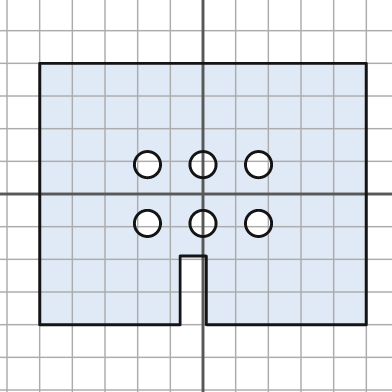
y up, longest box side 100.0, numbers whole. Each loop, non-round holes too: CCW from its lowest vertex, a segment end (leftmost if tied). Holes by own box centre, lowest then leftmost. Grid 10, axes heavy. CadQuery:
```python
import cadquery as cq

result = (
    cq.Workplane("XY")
    .moveTo(-50.0, -40.0)
    .lineTo(-7.0, -40.0)
    .lineTo(-7.0, -19.0)
    .lineTo(1.0, -19.0)
    .lineTo(1.0, -40.0)
    .lineTo(50.0, -40.0)
    .lineTo(50.0, 40.0)
    .lineTo(-50.0, 40.0)
    .close()
    .moveTo(-17.0, -9.0)
    .circle(4.0)
    .moveTo(0.0, -9.0)
    .circle(4.0)
    .moveTo(17.0, -9.0)
    .circle(4.0)
    .moveTo(-17.0, 9.0)
    .circle(4.0)
    .moveTo(0.0, 9.0)
    .circle(4.0)
    .moveTo(17.0, 9.0)
    .circle(4.0)
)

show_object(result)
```